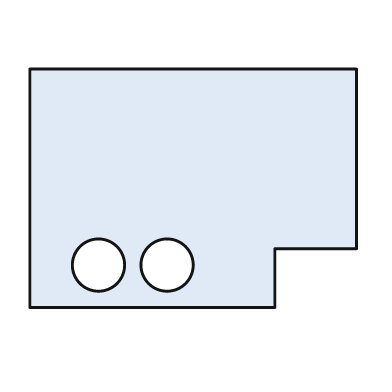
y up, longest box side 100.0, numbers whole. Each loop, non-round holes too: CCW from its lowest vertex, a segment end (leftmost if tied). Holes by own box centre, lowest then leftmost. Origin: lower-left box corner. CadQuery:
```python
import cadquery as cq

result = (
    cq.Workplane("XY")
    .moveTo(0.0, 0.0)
    .lineTo(75.0, 0.0)
    .lineTo(75.0, 18.0)
    .lineTo(100.0, 18.0)
    .lineTo(100.0, 73.0)
    .lineTo(0.0, 73.0)
    .close()
    .moveTo(21.0, 13.0)
    .circle(8.0)
    .moveTo(42.0, 13.0)
    .circle(8.0)
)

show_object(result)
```